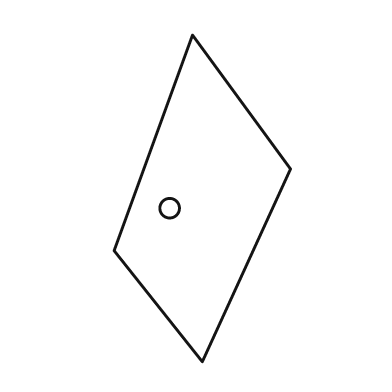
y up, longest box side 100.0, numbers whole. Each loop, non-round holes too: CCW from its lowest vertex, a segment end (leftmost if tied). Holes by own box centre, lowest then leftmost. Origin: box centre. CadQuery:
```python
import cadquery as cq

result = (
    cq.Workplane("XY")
    .moveTo(0.0, -50.0)
    .lineTo(27.0, 9.0)
    .lineTo(-3.0, 50.0)
    .lineTo(-27.0, -16.0)
    .close()
    .moveTo(-10.0, -3.0)
    .circle(3.0)
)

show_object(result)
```